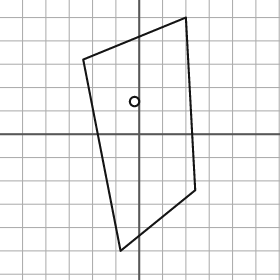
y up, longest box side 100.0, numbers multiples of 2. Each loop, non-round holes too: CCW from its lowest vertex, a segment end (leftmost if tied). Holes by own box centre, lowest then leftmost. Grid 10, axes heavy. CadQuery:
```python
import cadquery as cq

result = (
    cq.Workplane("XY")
    .moveTo(-8.0, -50.0)
    .lineTo(24.0, -24.0)
    .lineTo(20.0, 50.0)
    .lineTo(-24.0, 32.0)
    .close()
    .moveTo(-2.0, 14.0)
    .circle(2.0)
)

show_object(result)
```